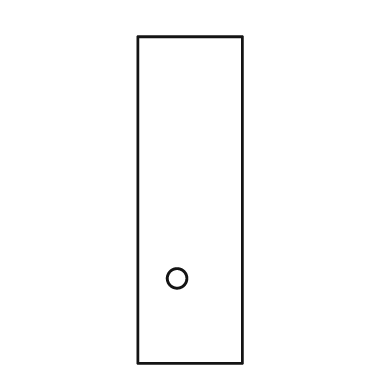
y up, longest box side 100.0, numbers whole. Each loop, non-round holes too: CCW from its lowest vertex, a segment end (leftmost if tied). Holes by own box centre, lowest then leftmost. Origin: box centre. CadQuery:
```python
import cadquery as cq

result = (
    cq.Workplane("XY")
    .moveTo(-16.0, -50.0)
    .lineTo(16.0, -50.0)
    .lineTo(16.0, 50.0)
    .lineTo(-16.0, 50.0)
    .close()
    .moveTo(-4.0, -24.0)
    .circle(3.0)
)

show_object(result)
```